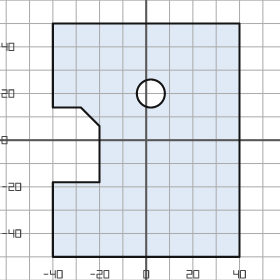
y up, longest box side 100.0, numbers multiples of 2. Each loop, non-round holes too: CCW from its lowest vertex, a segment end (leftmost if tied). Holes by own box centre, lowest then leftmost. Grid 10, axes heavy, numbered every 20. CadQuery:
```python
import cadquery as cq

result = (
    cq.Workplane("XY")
    .moveTo(-40.0, -50.0)
    .lineTo(40.0, -50.0)
    .lineTo(40.0, 50.0)
    .lineTo(-40.0, 50.0)
    .lineTo(-40.0, 14.0)
    .lineTo(-28.0, 14.0)
    .lineTo(-20.0, 6.0)
    .lineTo(-20.0, -18.0)
    .lineTo(-40.0, -18.0)
    .close()
    .moveTo(2.0, 20.0)
    .circle(6.0)
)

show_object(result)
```